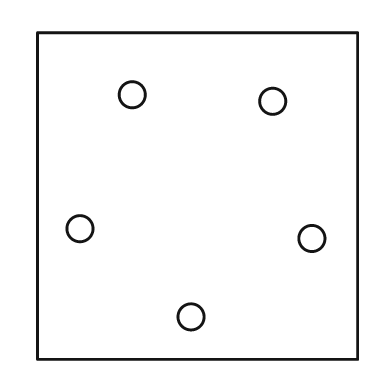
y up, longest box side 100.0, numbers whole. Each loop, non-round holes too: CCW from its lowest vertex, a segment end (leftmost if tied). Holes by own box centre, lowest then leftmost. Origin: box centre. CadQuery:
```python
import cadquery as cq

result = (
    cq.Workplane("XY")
    .moveTo(-49.0, -50.0)
    .lineTo(49.0, -50.0)
    .lineTo(49.0, 50.0)
    .lineTo(-49.0, 50.0)
    .close()
    .moveTo(-2.0, -37.0)
    .circle(4.0)
    .moveTo(35.0, -13.0)
    .circle(4.0)
    .moveTo(-36.0, -10.0)
    .circle(4.0)
    .moveTo(23.0, 29.0)
    .circle(4.0)
    .moveTo(-20.0, 31.0)
    .circle(4.0)
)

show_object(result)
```